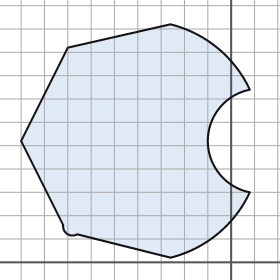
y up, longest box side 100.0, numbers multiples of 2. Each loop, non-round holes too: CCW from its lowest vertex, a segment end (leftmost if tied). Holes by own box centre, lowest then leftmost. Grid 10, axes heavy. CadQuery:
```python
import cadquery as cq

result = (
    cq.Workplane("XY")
    .moveTo(-26.0, 2.0)
    .threePointArc((-6.0, 12.0), (8.0, 30.0))
    .threePointArc((-10.0, 52.0), (8.0, 74.0))
    .threePointArc((-6.0, 92.0), (-26.0, 102.0))
    .lineTo(-70.0, 92.0)
    .lineTo(-90.0, 52.0)
    .lineTo(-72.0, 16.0)
    .threePointArc((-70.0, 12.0), (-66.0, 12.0))
    .close()
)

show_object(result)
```